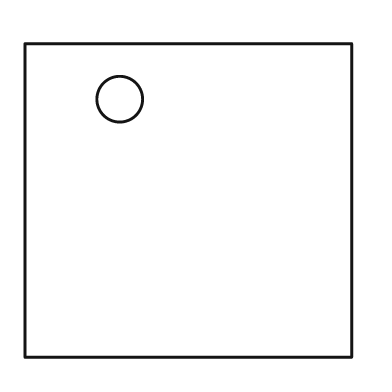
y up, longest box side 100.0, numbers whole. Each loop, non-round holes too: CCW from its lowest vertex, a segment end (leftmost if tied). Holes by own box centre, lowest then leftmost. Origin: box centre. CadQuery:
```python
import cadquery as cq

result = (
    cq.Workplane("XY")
    .moveTo(-50.0, -48.0)
    .lineTo(50.0, -48.0)
    .lineTo(50.0, 48.0)
    .lineTo(-50.0, 48.0)
    .close()
    .moveTo(-21.0, 31.0)
    .circle(7.0)
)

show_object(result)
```